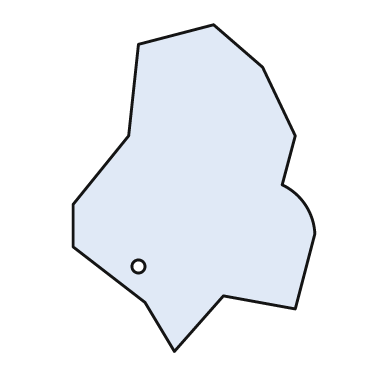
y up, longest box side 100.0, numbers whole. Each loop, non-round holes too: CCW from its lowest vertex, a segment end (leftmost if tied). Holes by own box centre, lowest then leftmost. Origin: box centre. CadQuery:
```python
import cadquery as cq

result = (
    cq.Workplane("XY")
    .moveTo(-6.0, -50.0)
    .lineTo(9.0, -33.0)
    .lineTo(31.0, -37.0)
    .lineTo(37.0, -14.0)
    .threePointArc((34.0, -5.0), (27.0, 1.0))
    .lineTo(31.0, 16.0)
    .lineTo(21.0, 37.0)
    .lineTo(6.0, 50.0)
    .lineTo(-17.0, 44.0)
    .lineTo(-20.0, 16.0)
    .lineTo(-37.0, -5.0)
    .lineTo(-37.0, -18.0)
    .lineTo(-15.0, -35.0)
    .close()
    .moveTo(-17.0, -24.0)
    .circle(2.0)
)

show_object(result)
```